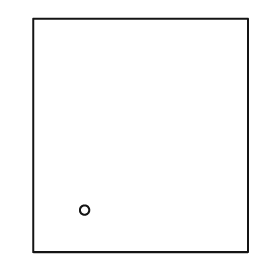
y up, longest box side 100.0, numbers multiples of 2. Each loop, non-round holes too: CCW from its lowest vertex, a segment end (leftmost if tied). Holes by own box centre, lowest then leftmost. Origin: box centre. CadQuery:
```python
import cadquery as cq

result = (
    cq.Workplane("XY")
    .moveTo(-46.0, -50.0)
    .lineTo(46.0, -50.0)
    .lineTo(46.0, 50.0)
    .lineTo(-46.0, 50.0)
    .close()
    .moveTo(-24.0, -32.0)
    .circle(2.0)
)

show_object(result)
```